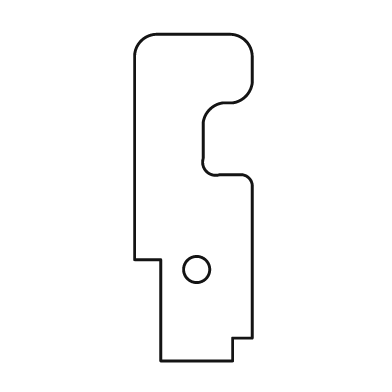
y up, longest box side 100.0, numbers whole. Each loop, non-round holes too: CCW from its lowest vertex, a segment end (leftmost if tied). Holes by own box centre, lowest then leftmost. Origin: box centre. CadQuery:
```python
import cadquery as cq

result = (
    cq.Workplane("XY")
    .moveTo(-10.0, -50.0)
    .lineTo(12.0, -50.0)
    .lineTo(12.0, -43.0)
    .lineTo(18.0, -43.0)
    .lineTo(18.0, 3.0)
    .threePointArc((17.0, 6.0), (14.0, 7.0))
    .lineTo(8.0, 7.0)
    .threePointArc((4.0, 8.0), (3.0, 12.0))
    .lineTo(3.0, 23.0)
    .threePointArc((5.0, 27.0), (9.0, 29.0))
    .lineTo(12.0, 29.0)
    .threePointArc((16.0, 31.0), (18.0, 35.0))
    .lineTo(18.0, 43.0)
    .threePointArc((16.0, 48.0), (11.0, 50.0))
    .lineTo(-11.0, 50.0)
    .threePointArc((-16.0, 48.0), (-18.0, 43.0))
    .lineTo(-18.0, -19.0)
    .lineTo(-10.0, -19.0)
    .close()
    .moveTo(1.0, -22.0)
    .circle(4.0)
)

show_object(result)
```